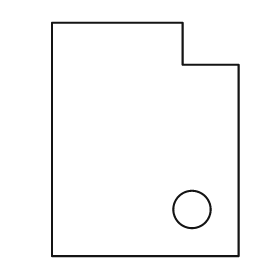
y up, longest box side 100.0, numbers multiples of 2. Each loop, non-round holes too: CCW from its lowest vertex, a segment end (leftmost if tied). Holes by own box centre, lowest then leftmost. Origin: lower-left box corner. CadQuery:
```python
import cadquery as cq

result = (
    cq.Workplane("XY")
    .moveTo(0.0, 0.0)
    .lineTo(80.0, 0.0)
    .lineTo(80.0, 82.0)
    .lineTo(56.0, 82.0)
    .lineTo(56.0, 100.0)
    .lineTo(0.0, 100.0)
    .close()
    .moveTo(60.0, 20.0)
    .circle(8.0)
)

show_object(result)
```